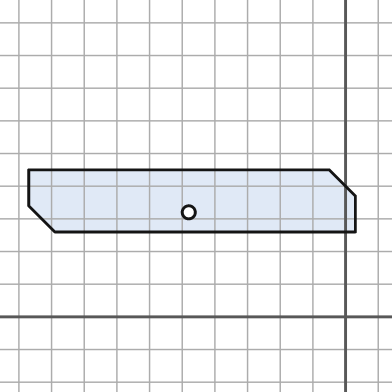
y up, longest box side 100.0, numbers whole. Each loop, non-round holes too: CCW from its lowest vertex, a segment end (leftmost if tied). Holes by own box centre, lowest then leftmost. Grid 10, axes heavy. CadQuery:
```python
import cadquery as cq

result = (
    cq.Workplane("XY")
    .moveTo(-89.0, 26.0)
    .lineTo(3.0, 26.0)
    .lineTo(3.0, 37.0)
    .lineTo(-5.0, 45.0)
    .lineTo(-97.0, 45.0)
    .lineTo(-97.0, 34.0)
    .close()
    .moveTo(-48.0, 32.0)
    .circle(2.0)
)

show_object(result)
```